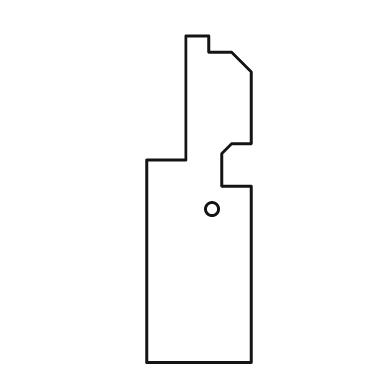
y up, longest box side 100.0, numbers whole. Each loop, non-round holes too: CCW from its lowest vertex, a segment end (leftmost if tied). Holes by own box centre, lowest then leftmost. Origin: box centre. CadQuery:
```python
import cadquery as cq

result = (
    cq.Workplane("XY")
    .moveTo(-16.0, -50.0)
    .lineTo(16.0, -50.0)
    .lineTo(16.0, 4.0)
    .lineTo(7.0, 4.0)
    .lineTo(7.0, 14.0)
    .lineTo(10.0, 17.0)
    .lineTo(16.0, 17.0)
    .lineTo(16.0, 39.0)
    .lineTo(10.0, 45.0)
    .lineTo(3.0, 45.0)
    .lineTo(3.0, 50.0)
    .lineTo(-4.0, 50.0)
    .lineTo(-4.0, 12.0)
    .lineTo(-16.0, 12.0)
    .close()
    .moveTo(4.0, -3.0)
    .circle(2.0)
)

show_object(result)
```